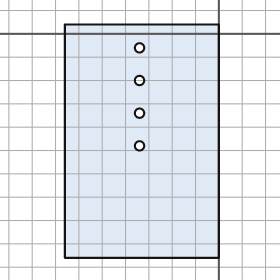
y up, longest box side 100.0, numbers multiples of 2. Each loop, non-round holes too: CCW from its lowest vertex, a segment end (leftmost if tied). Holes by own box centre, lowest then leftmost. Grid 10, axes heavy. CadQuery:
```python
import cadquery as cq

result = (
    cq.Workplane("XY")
    .moveTo(-66.0, -96.0)
    .lineTo(0.0, -96.0)
    .lineTo(0.0, 4.0)
    .lineTo(-66.0, 4.0)
    .close()
    .moveTo(-34.0, -48.0)
    .circle(2.0)
    .moveTo(-34.0, -34.0)
    .circle(2.0)
    .moveTo(-34.0, -20.0)
    .circle(2.0)
    .moveTo(-34.0, -6.0)
    .circle(2.0)
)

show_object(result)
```